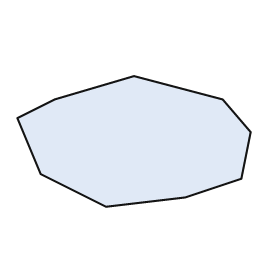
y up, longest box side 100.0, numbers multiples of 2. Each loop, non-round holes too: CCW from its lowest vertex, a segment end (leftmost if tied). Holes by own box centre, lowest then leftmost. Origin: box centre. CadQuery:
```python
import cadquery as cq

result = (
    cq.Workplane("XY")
    .moveTo(-12.0, -28.0)
    .lineTo(22.0, -24.0)
    .lineTo(46.0, -16.0)
    .lineTo(50.0, 4.0)
    .lineTo(38.0, 18.0)
    .lineTo(0.0, 28.0)
    .lineTo(-34.0, 18.0)
    .lineTo(-50.0, 10.0)
    .lineTo(-40.0, -14.0)
    .close()
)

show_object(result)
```